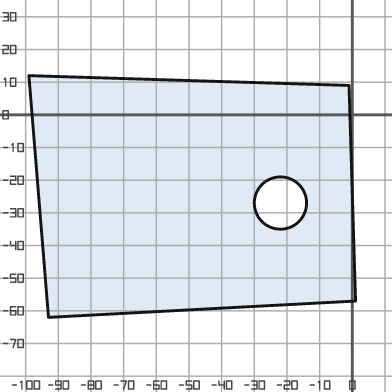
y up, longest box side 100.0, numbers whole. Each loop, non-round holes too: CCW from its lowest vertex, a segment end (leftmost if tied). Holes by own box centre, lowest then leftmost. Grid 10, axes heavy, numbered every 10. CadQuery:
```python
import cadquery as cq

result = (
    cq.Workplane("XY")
    .moveTo(-93.0, -62.0)
    .lineTo(1.0, -57.0)
    .lineTo(-1.0, 9.0)
    .lineTo(-99.0, 12.0)
    .close()
    .moveTo(-22.0, -27.0)
    .circle(8.0)
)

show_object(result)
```